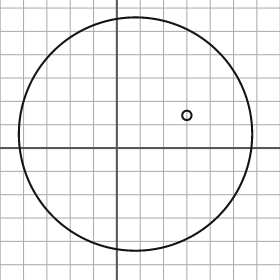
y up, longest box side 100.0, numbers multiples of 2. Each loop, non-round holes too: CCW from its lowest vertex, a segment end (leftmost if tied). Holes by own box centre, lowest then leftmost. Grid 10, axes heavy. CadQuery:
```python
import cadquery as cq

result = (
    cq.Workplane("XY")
    .moveTo(8.0, 6.0)
    .circle(50.0)
    .moveTo(30.0, 14.0)
    .circle(2.0)
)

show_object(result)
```